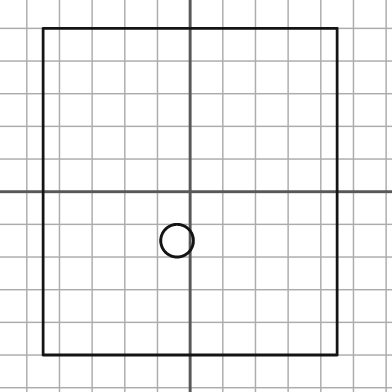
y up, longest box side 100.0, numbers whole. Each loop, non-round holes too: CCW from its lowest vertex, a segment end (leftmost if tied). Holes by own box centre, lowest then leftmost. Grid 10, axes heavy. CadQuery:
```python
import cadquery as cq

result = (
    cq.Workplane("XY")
    .moveTo(-45.0, -50.0)
    .lineTo(45.0, -50.0)
    .lineTo(45.0, 50.0)
    .lineTo(-45.0, 50.0)
    .close()
    .moveTo(-4.0, -15.0)
    .circle(5.0)
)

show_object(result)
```